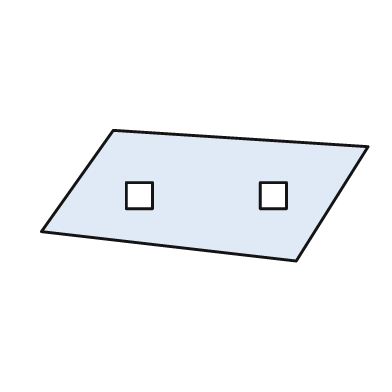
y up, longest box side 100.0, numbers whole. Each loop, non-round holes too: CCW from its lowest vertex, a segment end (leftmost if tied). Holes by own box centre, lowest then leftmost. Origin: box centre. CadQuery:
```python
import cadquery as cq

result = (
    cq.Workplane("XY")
    .moveTo(28.0, -20.0)
    .lineTo(50.0, 15.0)
    .lineTo(-28.0, 20.0)
    .lineTo(-50.0, -11.0)
    .close()
    .moveTo(-24.0, -4.0)
    .lineTo(-16.0, -4.0)
    .lineTo(-16.0, 4.0)
    .lineTo(-24.0, 4.0)
    .close()
    .moveTo(17.0, -4.0)
    .lineTo(25.0, -4.0)
    .lineTo(25.0, 4.0)
    .lineTo(17.0, 4.0)
    .close()
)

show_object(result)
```